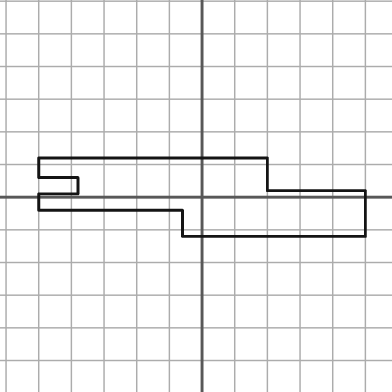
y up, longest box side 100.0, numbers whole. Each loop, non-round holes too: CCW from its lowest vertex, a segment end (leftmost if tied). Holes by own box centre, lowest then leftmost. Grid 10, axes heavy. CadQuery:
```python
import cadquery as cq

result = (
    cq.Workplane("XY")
    .moveTo(-6.0, -12.0)
    .lineTo(50.0, -12.0)
    .lineTo(50.0, 2.0)
    .lineTo(20.0, 2.0)
    .lineTo(20.0, 12.0)
    .lineTo(-50.0, 12.0)
    .lineTo(-50.0, 6.0)
    .lineTo(-38.0, 6.0)
    .lineTo(-38.0, 1.0)
    .lineTo(-50.0, 1.0)
    .lineTo(-50.0, -4.0)
    .lineTo(-6.0, -4.0)
    .close()
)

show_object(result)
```